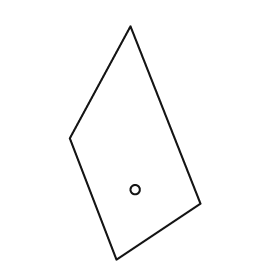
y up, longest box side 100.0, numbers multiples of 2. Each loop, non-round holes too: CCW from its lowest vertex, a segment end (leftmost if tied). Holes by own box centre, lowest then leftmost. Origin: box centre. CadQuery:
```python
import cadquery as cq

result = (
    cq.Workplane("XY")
    .moveTo(-8.0, -50.0)
    .lineTo(28.0, -26.0)
    .lineTo(-2.0, 50.0)
    .lineTo(-28.0, 2.0)
    .close()
    .moveTo(0.0, -20.0)
    .circle(2.0)
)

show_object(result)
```